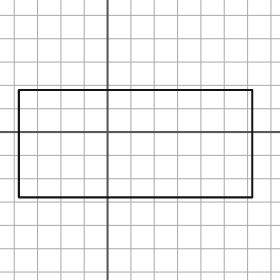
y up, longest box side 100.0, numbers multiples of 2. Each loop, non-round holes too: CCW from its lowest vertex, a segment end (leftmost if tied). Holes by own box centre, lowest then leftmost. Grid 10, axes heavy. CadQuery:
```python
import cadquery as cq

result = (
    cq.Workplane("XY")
    .moveTo(-38.0, -28.0)
    .lineTo(62.0, -28.0)
    .lineTo(62.0, 18.0)
    .lineTo(-38.0, 18.0)
    .close()
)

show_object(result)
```